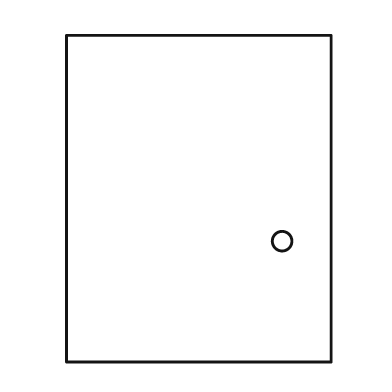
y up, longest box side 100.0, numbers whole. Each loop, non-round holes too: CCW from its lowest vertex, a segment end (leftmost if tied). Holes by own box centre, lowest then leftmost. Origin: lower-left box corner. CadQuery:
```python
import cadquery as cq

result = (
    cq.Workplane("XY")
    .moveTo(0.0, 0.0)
    .lineTo(81.0, 0.0)
    .lineTo(81.0, 100.0)
    .lineTo(0.0, 100.0)
    .close()
    .moveTo(66.0, 37.0)
    .circle(3.0)
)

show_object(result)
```